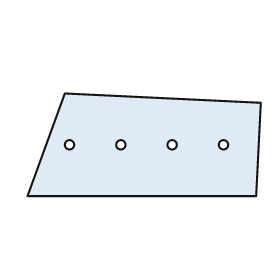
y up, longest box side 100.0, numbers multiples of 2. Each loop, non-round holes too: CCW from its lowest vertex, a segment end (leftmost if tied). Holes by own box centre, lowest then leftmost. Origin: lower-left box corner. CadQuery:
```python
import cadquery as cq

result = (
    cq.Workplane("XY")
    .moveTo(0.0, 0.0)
    .lineTo(98.0, 0.0)
    .lineTo(100.0, 40.0)
    .lineTo(16.0, 44.0)
    .close()
    .moveTo(18.0, 22.0)
    .circle(2.0)
    .moveTo(40.0, 22.0)
    .circle(2.0)
    .moveTo(62.0, 22.0)
    .circle(2.0)
    .moveTo(84.0, 22.0)
    .circle(2.0)
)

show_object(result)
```